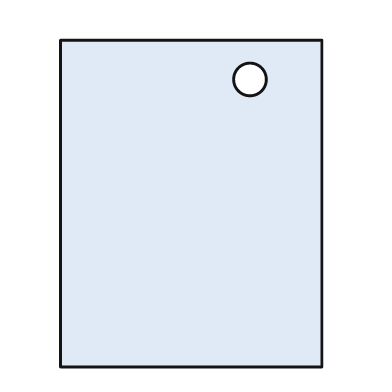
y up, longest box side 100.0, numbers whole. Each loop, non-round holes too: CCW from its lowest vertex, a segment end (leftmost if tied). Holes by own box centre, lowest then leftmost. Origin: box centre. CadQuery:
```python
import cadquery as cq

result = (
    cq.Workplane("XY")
    .moveTo(-40.0, -50.0)
    .lineTo(40.0, -50.0)
    .lineTo(40.0, 50.0)
    .lineTo(-40.0, 50.0)
    .close()
    .moveTo(18.0, 38.0)
    .circle(5.0)
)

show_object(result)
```